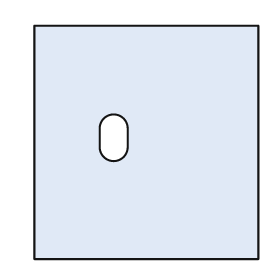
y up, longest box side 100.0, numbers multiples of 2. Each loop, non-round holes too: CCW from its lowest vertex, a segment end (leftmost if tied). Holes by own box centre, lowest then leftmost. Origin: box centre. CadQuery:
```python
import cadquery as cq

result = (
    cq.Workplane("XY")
    .moveTo(-48.0, -50.0)
    .lineTo(48.0, -50.0)
    .lineTo(48.0, 50.0)
    .lineTo(-48.0, 50.0)
    .close()
    .moveTo(-20.0, -2.0)
    .threePointArc((-14.0, -8.0), (-8.0, -2.0))
    .lineTo(-8.0, 6.0)
    .threePointArc((-14.0, 12.0), (-20.0, 6.0))
    .close()
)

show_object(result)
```